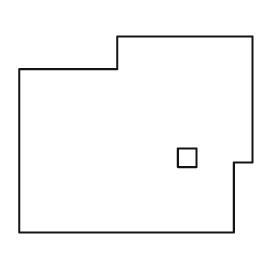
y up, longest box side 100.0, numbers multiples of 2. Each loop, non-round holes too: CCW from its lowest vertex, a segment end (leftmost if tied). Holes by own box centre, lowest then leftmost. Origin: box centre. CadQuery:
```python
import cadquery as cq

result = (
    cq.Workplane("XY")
    .moveTo(-50.0, -42.0)
    .lineTo(42.0, -42.0)
    .lineTo(42.0, -12.0)
    .lineTo(50.0, -12.0)
    .lineTo(50.0, 42.0)
    .lineTo(-8.0, 42.0)
    .lineTo(-8.0, 28.0)
    .lineTo(-50.0, 28.0)
    .close()
    .moveTo(18.0, -14.0)
    .lineTo(26.0, -14.0)
    .lineTo(26.0, -6.0)
    .lineTo(18.0, -6.0)
    .close()
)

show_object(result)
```